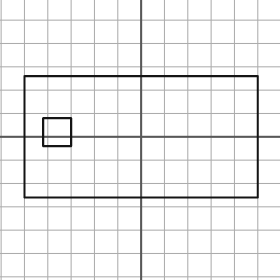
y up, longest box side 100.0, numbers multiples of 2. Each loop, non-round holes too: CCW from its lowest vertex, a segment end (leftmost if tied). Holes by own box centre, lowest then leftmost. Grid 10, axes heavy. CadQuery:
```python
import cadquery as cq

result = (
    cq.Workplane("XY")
    .moveTo(-50.0, -26.0)
    .lineTo(50.0, -26.0)
    .lineTo(50.0, 26.0)
    .lineTo(-50.0, 26.0)
    .close()
    .moveTo(-42.0, -4.0)
    .lineTo(-30.0, -4.0)
    .lineTo(-30.0, 8.0)
    .lineTo(-42.0, 8.0)
    .close()
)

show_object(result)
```